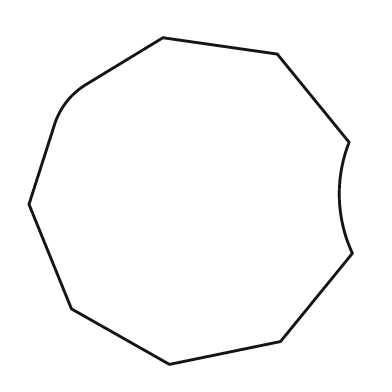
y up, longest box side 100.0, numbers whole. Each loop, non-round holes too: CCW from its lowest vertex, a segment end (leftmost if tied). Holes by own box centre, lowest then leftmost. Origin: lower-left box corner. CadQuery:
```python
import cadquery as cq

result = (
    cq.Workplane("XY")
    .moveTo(43.0, 0.0)
    .lineTo(77.0, 7.0)
    .lineTo(99.0, 34.0)
    .threePointArc((95.0, 51.0), (98.0, 68.0))
    .lineTo(76.0, 95.0)
    .lineTo(41.0, 100.0)
    .lineTo(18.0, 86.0)
    .threePointArc((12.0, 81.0), (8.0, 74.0))
    .lineTo(0.0, 49.0)
    .lineTo(13.0, 17.0)
    .close()
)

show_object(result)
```